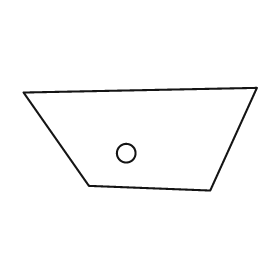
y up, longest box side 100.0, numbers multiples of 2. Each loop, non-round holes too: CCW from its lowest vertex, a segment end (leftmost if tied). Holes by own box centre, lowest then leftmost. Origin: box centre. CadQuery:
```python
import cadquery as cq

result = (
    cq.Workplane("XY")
    .moveTo(30.0, -22.0)
    .lineTo(50.0, 22.0)
    .lineTo(-50.0, 20.0)
    .lineTo(-22.0, -20.0)
    .close()
    .moveTo(-6.0, -6.0)
    .circle(4.0)
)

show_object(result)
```